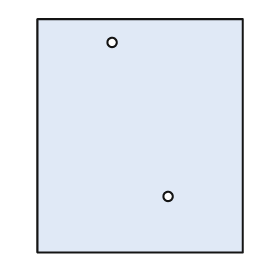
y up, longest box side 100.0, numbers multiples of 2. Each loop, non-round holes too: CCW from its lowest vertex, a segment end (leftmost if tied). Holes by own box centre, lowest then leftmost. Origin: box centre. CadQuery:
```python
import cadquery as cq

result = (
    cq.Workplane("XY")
    .moveTo(-44.0, -50.0)
    .lineTo(44.0, -50.0)
    .lineTo(44.0, 50.0)
    .lineTo(-44.0, 50.0)
    .close()
    .moveTo(12.0, -26.0)
    .circle(2.0)
    .moveTo(-12.0, 40.0)
    .circle(2.0)
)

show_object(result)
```